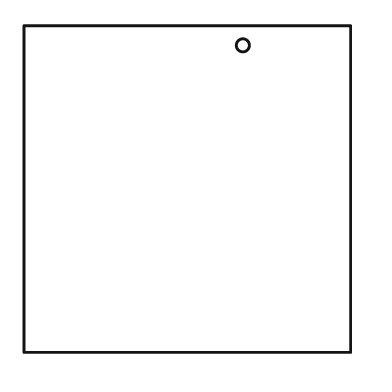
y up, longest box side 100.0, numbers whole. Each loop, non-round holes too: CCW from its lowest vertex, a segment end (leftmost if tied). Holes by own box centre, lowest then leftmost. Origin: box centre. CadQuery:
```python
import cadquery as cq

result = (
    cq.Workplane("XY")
    .moveTo(-50.0, -50.0)
    .lineTo(50.0, -50.0)
    .lineTo(50.0, 50.0)
    .lineTo(-50.0, 50.0)
    .close()
    .moveTo(17.0, 44.0)
    .circle(2.0)
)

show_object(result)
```